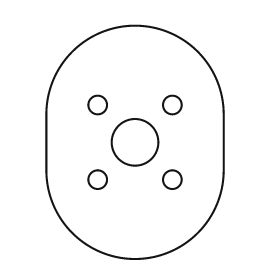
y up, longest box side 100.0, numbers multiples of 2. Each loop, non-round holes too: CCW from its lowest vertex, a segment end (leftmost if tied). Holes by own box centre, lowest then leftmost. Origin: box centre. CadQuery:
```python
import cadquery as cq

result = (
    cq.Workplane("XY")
    .moveTo(-38.0, -12.0)
    .threePointArc((0.0, -50.0), (38.0, -12.0))
    .lineTo(38.0, 12.0)
    .threePointArc((0.0, 50.0), (-38.0, 12.0))
    .close()
    .moveTo(-16.0, -16.0)
    .circle(4.0)
    .moveTo(16.0, -16.0)
    .circle(4.0)
    .moveTo(0.0, 0.0)
    .circle(10.0)
    .moveTo(-16.0, 16.0)
    .circle(4.0)
    .moveTo(16.0, 16.0)
    .circle(4.0)
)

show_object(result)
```